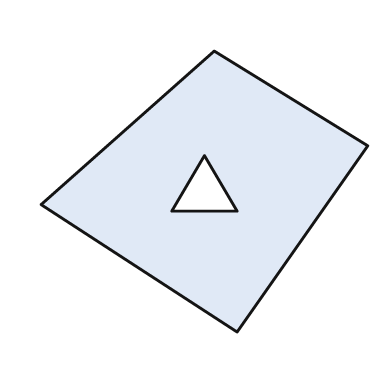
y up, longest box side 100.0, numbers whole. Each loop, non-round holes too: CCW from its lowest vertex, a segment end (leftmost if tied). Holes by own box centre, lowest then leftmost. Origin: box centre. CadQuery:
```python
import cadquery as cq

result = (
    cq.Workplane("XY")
    .moveTo(10.0, -43.0)
    .lineTo(50.0, 14.0)
    .lineTo(3.0, 43.0)
    .lineTo(-50.0, -4.0)
    .close()
    .moveTo(-10.0, -6.0)
    .lineTo(10.0, -6.0)
    .lineTo(0.0, 11.0)
    .close()
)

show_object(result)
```